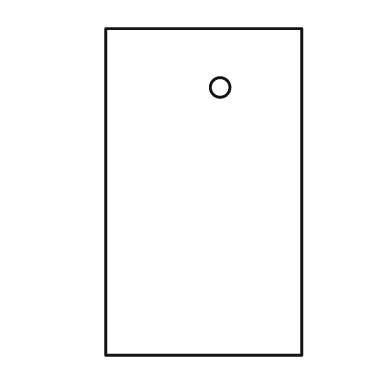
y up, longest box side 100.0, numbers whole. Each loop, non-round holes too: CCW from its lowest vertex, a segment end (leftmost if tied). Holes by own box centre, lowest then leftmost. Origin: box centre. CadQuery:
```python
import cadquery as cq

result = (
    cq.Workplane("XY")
    .moveTo(-30.0, -50.0)
    .lineTo(30.0, -50.0)
    .lineTo(30.0, 50.0)
    .lineTo(-30.0, 50.0)
    .close()
    .moveTo(5.0, 32.0)
    .circle(3.0)
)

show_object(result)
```